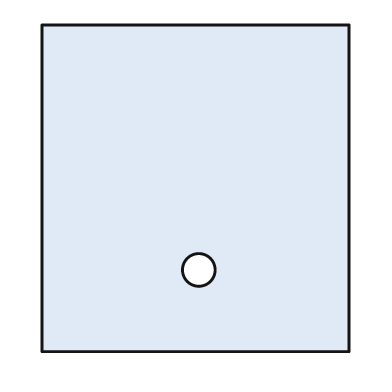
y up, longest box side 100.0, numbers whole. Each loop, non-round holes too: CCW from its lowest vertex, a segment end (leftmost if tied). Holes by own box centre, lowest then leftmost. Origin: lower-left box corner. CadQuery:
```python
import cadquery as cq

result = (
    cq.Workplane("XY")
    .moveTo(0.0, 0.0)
    .lineTo(94.0, 0.0)
    .lineTo(94.0, 100.0)
    .lineTo(0.0, 100.0)
    .close()
    .moveTo(48.0, 25.0)
    .circle(5.0)
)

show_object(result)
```